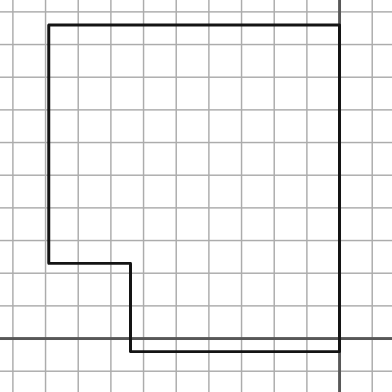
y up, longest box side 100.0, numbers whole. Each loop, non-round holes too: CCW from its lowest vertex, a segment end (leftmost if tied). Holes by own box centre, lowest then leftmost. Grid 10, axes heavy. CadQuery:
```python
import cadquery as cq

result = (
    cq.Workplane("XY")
    .moveTo(-64.0, -4.0)
    .lineTo(0.0, -4.0)
    .lineTo(0.0, 96.0)
    .lineTo(-89.0, 96.0)
    .lineTo(-89.0, 23.0)
    .lineTo(-64.0, 23.0)
    .close()
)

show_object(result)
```